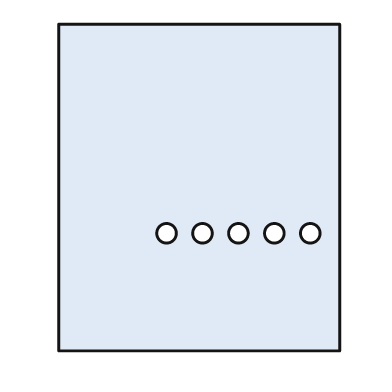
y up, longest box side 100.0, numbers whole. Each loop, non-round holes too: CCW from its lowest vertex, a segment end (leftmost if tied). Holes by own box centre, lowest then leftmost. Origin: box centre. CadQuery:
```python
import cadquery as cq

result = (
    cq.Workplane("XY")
    .moveTo(-43.0, -50.0)
    .lineTo(43.0, -50.0)
    .lineTo(43.0, 50.0)
    .lineTo(-43.0, 50.0)
    .close()
    .moveTo(-10.0, -14.0)
    .circle(3.0)
    .moveTo(1.0, -14.0)
    .circle(3.0)
    .moveTo(12.0, -14.0)
    .circle(3.0)
    .moveTo(23.0, -14.0)
    .circle(3.0)
    .moveTo(34.0, -14.0)
    .circle(3.0)
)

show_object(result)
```